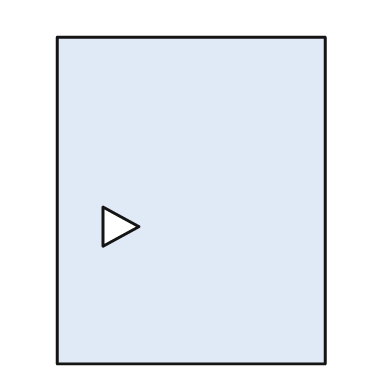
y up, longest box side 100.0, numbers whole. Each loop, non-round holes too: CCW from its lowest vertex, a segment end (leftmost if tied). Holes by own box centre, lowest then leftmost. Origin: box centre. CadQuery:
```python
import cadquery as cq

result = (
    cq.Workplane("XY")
    .moveTo(-41.0, -50.0)
    .lineTo(41.0, -50.0)
    .lineTo(41.0, 50.0)
    .lineTo(-41.0, 50.0)
    .close()
    .moveTo(-27.0, -14.0)
    .lineTo(-16.0, -8.0)
    .lineTo(-27.0, -2.0)
    .close()
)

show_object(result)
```